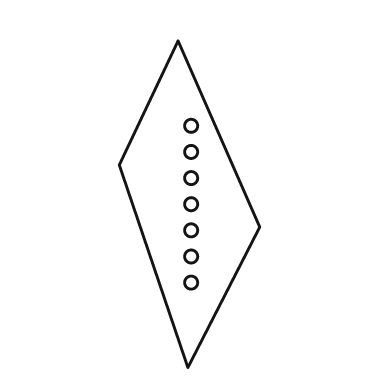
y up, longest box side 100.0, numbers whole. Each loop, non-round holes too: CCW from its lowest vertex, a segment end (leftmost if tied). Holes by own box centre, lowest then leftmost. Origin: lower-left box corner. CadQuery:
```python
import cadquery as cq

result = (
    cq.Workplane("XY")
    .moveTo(21.0, 0.0)
    .lineTo(43.0, 43.0)
    .lineTo(18.0, 100.0)
    .lineTo(0.0, 62.0)
    .close()
    .moveTo(22.0, 26.0)
    .circle(2.0)
    .moveTo(22.0, 34.0)
    .circle(2.0)
    .moveTo(22.0, 42.0)
    .circle(2.0)
    .moveTo(22.0, 50.0)
    .circle(2.0)
    .moveTo(22.0, 58.0)
    .circle(2.0)
    .moveTo(22.0, 66.0)
    .circle(2.0)
    .moveTo(22.0, 74.0)
    .circle(2.0)
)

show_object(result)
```